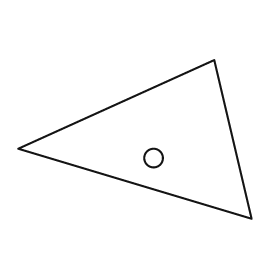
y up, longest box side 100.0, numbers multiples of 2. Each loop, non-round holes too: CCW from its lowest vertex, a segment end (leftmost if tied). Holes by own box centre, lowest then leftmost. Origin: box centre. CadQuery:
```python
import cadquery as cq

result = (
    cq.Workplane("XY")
    .moveTo(50.0, -34.0)
    .lineTo(34.0, 34.0)
    .lineTo(-50.0, -4.0)
    .close()
    .moveTo(8.0, -8.0)
    .circle(4.0)
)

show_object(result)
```